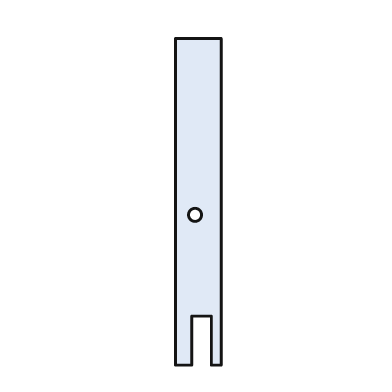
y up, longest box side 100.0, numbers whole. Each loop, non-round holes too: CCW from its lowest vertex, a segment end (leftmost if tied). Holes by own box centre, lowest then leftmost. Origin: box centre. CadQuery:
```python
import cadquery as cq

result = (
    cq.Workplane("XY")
    .moveTo(-7.0, -50.0)
    .lineTo(-2.0, -50.0)
    .lineTo(-2.0, -35.0)
    .lineTo(4.0, -35.0)
    .lineTo(4.0, -50.0)
    .lineTo(7.0, -50.0)
    .lineTo(7.0, 50.0)
    .lineTo(-7.0, 50.0)
    .close()
    .moveTo(-1.0, -4.0)
    .circle(2.0)
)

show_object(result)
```